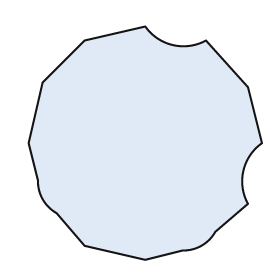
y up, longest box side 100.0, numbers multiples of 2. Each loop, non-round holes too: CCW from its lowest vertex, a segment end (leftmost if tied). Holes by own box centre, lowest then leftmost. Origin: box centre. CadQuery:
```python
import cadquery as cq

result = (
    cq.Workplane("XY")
    .moveTo(0.0, -50.0)
    .lineTo(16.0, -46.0)
    .threePointArc((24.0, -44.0), (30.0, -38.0))
    .lineTo(44.0, -26.0)
    .threePointArc((42.0, -12.0), (50.0, 0.0))
    .lineTo(44.0, 24.0)
    .lineTo(26.0, 44.0)
    .threePointArc((12.0, 42.0), (0.0, 50.0))
    .lineTo(-26.0, 44.0)
    .lineTo(-44.0, 26.0)
    .lineTo(-50.0, 0.0)
    .lineTo(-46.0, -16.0)
    .threePointArc((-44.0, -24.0), (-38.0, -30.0))
    .lineTo(-26.0, -44.0)
    .close()
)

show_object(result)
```